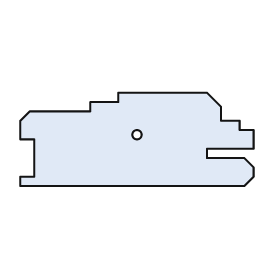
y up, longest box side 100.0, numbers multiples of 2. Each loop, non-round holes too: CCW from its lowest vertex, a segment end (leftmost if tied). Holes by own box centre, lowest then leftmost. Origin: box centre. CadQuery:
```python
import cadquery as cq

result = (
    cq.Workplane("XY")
    .moveTo(-50.0, -20.0)
    .lineTo(46.0, -20.0)
    .lineTo(50.0, -16.0)
    .lineTo(50.0, -12.0)
    .lineTo(46.0, -8.0)
    .lineTo(30.0, -8.0)
    .lineTo(30.0, -4.0)
    .lineTo(50.0, -4.0)
    .lineTo(50.0, 4.0)
    .lineTo(44.0, 4.0)
    .lineTo(44.0, 8.0)
    .lineTo(36.0, 8.0)
    .lineTo(36.0, 14.0)
    .lineTo(30.0, 20.0)
    .lineTo(-8.0, 20.0)
    .lineTo(-8.0, 16.0)
    .lineTo(-20.0, 16.0)
    .lineTo(-20.0, 12.0)
    .lineTo(-46.0, 12.0)
    .lineTo(-50.0, 8.0)
    .lineTo(-50.0, 0.0)
    .lineTo(-44.0, 0.0)
    .lineTo(-44.0, -16.0)
    .lineTo(-50.0, -16.0)
    .close()
    .moveTo(0.0, 2.0)
    .circle(2.0)
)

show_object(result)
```